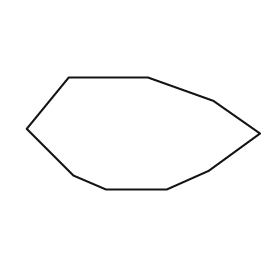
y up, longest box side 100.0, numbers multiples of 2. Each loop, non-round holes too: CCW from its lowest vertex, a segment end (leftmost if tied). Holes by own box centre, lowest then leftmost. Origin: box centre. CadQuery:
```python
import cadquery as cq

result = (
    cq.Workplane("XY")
    .moveTo(-16.0, -24.0)
    .lineTo(10.0, -24.0)
    .lineTo(28.0, -16.0)
    .lineTo(50.0, 0.0)
    .lineTo(30.0, 14.0)
    .lineTo(2.0, 24.0)
    .lineTo(-32.0, 24.0)
    .lineTo(-50.0, 2.0)
    .lineTo(-30.0, -18.0)
    .close()
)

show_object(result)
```